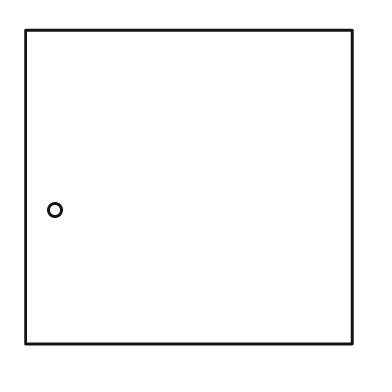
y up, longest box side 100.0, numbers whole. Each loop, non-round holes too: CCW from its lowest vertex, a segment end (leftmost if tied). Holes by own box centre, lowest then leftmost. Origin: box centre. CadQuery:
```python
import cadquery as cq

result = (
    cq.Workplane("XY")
    .moveTo(-50.0, -48.0)
    .lineTo(50.0, -48.0)
    .lineTo(50.0, 48.0)
    .lineTo(-50.0, 48.0)
    .close()
    .moveTo(-41.0, -7.0)
    .circle(2.0)
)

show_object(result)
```